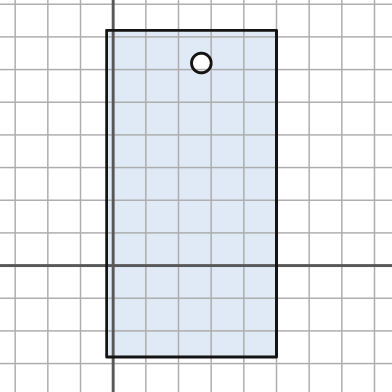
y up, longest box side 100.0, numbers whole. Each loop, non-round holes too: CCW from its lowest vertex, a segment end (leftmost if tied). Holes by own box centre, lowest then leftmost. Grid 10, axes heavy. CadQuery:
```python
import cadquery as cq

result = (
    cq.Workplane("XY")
    .moveTo(-2.0, -28.0)
    .lineTo(50.0, -28.0)
    .lineTo(50.0, 72.0)
    .lineTo(-2.0, 72.0)
    .close()
    .moveTo(27.0, 62.0)
    .circle(3.0)
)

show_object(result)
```